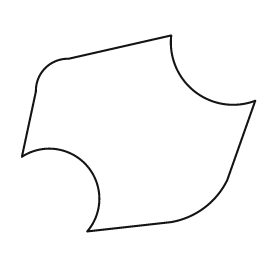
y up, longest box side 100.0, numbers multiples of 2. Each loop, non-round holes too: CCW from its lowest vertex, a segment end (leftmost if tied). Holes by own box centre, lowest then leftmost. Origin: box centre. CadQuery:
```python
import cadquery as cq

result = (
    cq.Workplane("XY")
    .moveTo(-22.0, -42.0)
    .lineTo(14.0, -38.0)
    .threePointArc((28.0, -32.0), (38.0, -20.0))
    .lineTo(50.0, 14.0)
    .threePointArc((24.0, 18.0), (14.0, 42.0))
    .lineTo(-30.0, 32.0)
    .threePointArc((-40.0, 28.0), (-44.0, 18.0))
    .lineTo(-50.0, -10.0)
    .threePointArc((-22.0, -14.0), (-22.0, -42.0))
    .close()
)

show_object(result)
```